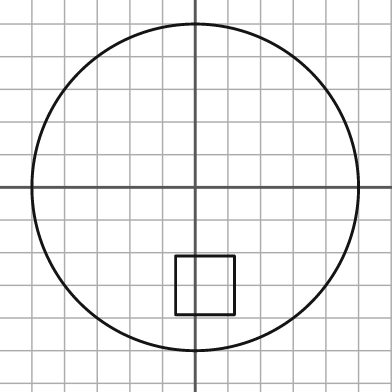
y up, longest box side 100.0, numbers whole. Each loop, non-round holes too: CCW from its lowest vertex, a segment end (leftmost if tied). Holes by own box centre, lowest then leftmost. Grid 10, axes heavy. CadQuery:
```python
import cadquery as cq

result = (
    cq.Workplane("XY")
    .moveTo(0.0, 0.0)
    .circle(50.0)
    .moveTo(-6.0, -39.0)
    .lineTo(12.0, -39.0)
    .lineTo(12.0, -21.0)
    .lineTo(-6.0, -21.0)
    .close()
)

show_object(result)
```